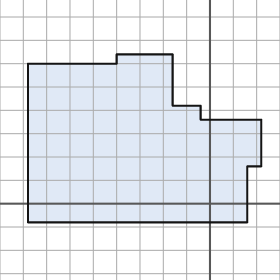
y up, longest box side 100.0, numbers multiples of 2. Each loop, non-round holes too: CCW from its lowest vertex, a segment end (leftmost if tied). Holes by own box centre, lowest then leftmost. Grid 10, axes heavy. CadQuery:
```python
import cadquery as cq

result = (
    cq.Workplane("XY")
    .moveTo(-78.0, -8.0)
    .lineTo(16.0, -8.0)
    .lineTo(16.0, 16.0)
    .lineTo(22.0, 16.0)
    .lineTo(22.0, 36.0)
    .lineTo(-4.0, 36.0)
    .lineTo(-4.0, 42.0)
    .lineTo(-16.0, 42.0)
    .lineTo(-16.0, 64.0)
    .lineTo(-40.0, 64.0)
    .lineTo(-40.0, 60.0)
    .lineTo(-78.0, 60.0)
    .close()
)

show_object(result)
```